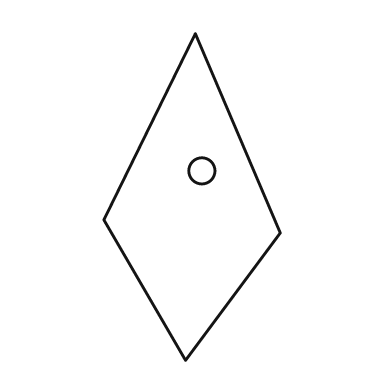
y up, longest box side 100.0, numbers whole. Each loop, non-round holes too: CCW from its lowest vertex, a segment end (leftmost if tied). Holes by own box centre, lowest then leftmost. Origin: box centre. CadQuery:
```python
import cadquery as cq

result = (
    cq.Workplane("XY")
    .moveTo(-2.0, -50.0)
    .lineTo(27.0, -11.0)
    .lineTo(1.0, 50.0)
    .lineTo(-27.0, -7.0)
    .close()
    .moveTo(3.0, 8.0)
    .circle(4.0)
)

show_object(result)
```